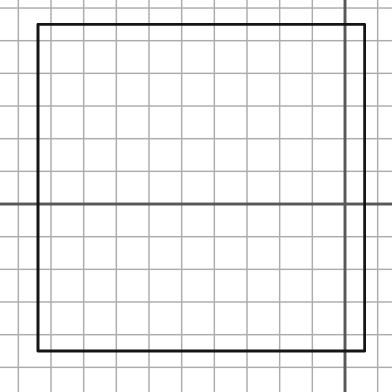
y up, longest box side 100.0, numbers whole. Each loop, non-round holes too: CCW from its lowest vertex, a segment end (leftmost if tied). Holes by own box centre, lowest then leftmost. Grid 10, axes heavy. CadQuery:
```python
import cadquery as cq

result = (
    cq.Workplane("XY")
    .moveTo(-94.0, -45.0)
    .lineTo(6.0, -45.0)
    .lineTo(6.0, 55.0)
    .lineTo(-94.0, 55.0)
    .close()
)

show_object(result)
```